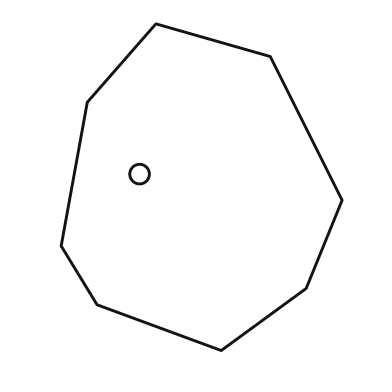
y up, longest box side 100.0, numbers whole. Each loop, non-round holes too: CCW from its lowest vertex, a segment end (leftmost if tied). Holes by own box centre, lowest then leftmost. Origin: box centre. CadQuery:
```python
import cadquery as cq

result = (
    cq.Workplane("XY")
    .moveTo(6.0, -50.0)
    .lineTo(32.0, -31.0)
    .lineTo(43.0, -4.0)
    .lineTo(21.0, 40.0)
    .lineTo(-14.0, 50.0)
    .lineTo(-35.0, 26.0)
    .lineTo(-43.0, -18.0)
    .lineTo(-32.0, -36.0)
    .close()
    .moveTo(-19.0, 4.0)
    .circle(3.0)
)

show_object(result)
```